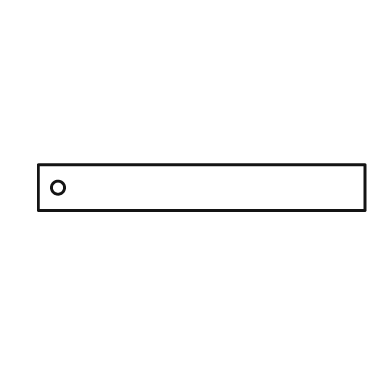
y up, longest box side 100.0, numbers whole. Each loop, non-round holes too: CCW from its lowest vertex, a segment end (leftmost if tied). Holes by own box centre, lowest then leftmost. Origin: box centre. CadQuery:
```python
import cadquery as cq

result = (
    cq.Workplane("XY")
    .moveTo(-50.0, -7.0)
    .lineTo(50.0, -7.0)
    .lineTo(50.0, 7.0)
    .lineTo(-50.0, 7.0)
    .close()
    .moveTo(-44.0, 0.0)
    .circle(2.0)
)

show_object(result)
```